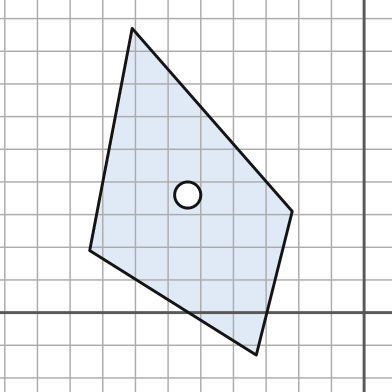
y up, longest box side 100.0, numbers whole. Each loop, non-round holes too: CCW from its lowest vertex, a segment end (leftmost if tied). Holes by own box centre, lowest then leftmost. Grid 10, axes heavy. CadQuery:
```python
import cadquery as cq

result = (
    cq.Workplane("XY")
    .moveTo(-33.0, -13.0)
    .lineTo(-22.0, 31.0)
    .lineTo(-71.0, 87.0)
    .lineTo(-84.0, 19.0)
    .close()
    .moveTo(-54.0, 36.0)
    .circle(4.0)
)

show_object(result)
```